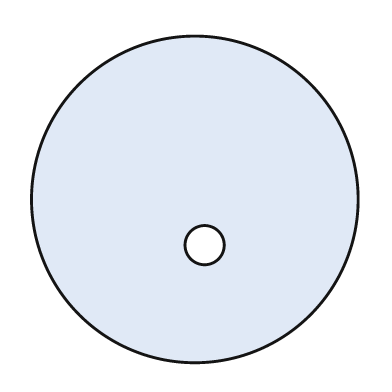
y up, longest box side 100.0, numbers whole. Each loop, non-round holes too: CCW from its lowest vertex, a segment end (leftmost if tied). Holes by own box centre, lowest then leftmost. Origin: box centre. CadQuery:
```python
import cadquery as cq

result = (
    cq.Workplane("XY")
    .moveTo(0.0, 0.0)
    .circle(50.0)
    .moveTo(3.0, -14.0)
    .circle(6.0)
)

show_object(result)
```